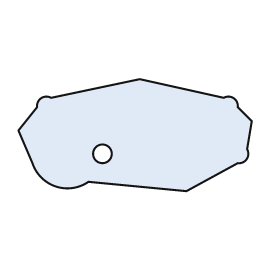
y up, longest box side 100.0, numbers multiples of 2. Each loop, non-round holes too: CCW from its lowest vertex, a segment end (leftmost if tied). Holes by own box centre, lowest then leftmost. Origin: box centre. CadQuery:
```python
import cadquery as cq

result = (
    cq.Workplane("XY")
    .moveTo(22.0, -24.0)
    .lineTo(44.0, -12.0)
    .threePointArc((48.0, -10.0), (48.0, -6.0))
    .lineTo(50.0, 6.0)
    .lineTo(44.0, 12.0)
    .threePointArc((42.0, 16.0), (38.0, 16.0))
    .lineTo(2.0, 24.0)
    .lineTo(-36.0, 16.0)
    .threePointArc((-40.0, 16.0), (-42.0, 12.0))
    .lineTo(-50.0, 2.0)
    .lineTo(-44.0, -12.0)
    .threePointArc((-34.0, -22.0), (-20.0, -20.0))
    .close()
    .moveTo(-14.0, -8.0)
    .circle(4.0)
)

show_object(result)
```